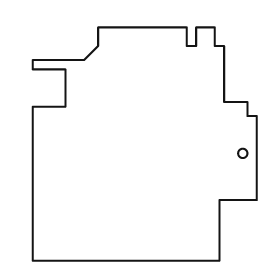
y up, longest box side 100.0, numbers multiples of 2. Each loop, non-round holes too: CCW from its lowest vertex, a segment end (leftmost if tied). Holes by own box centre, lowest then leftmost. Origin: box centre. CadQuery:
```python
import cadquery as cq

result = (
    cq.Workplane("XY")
    .moveTo(-48.0, -50.0)
    .lineTo(32.0, -50.0)
    .lineTo(32.0, -24.0)
    .lineTo(48.0, -24.0)
    .lineTo(48.0, 12.0)
    .lineTo(44.0, 12.0)
    .lineTo(44.0, 18.0)
    .lineTo(34.0, 18.0)
    .lineTo(34.0, 42.0)
    .lineTo(30.0, 42.0)
    .lineTo(30.0, 50.0)
    .lineTo(22.0, 50.0)
    .lineTo(22.0, 42.0)
    .lineTo(18.0, 42.0)
    .lineTo(18.0, 50.0)
    .lineTo(-20.0, 50.0)
    .lineTo(-20.0, 42.0)
    .lineTo(-26.0, 36.0)
    .lineTo(-48.0, 36.0)
    .lineTo(-48.0, 32.0)
    .lineTo(-34.0, 32.0)
    .lineTo(-34.0, 16.0)
    .lineTo(-48.0, 16.0)
    .close()
    .moveTo(42.0, -4.0)
    .circle(2.0)
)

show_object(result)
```